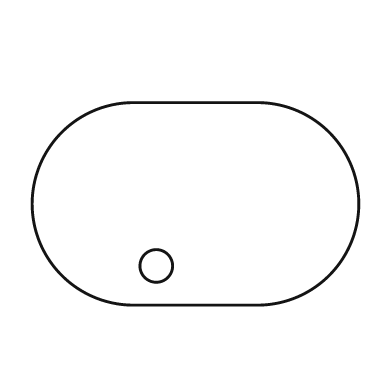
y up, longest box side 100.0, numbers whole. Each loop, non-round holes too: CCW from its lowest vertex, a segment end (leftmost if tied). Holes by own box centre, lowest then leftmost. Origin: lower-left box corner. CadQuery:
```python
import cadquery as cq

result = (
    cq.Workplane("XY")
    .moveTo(31.0, 0.0)
    .lineTo(69.0, 0.0)
    .threePointArc((100.0, 31.0), (69.0, 62.0))
    .lineTo(31.0, 62.0)
    .threePointArc((0.0, 31.0), (31.0, 0.0))
    .close()
    .moveTo(38.0, 12.0)
    .circle(5.0)
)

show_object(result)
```